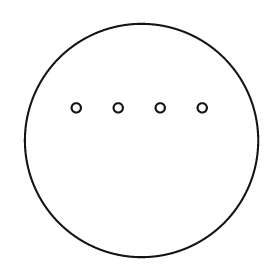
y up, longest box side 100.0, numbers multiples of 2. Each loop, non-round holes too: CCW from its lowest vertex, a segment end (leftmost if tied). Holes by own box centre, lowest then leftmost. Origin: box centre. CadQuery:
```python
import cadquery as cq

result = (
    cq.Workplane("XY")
    .moveTo(0.0, 0.0)
    .circle(50.0)
    .moveTo(-28.0, 14.0)
    .circle(2.0)
    .moveTo(-10.0, 14.0)
    .circle(2.0)
    .moveTo(8.0, 14.0)
    .circle(2.0)
    .moveTo(26.0, 14.0)
    .circle(2.0)
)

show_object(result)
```